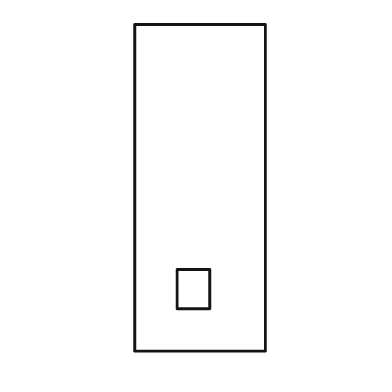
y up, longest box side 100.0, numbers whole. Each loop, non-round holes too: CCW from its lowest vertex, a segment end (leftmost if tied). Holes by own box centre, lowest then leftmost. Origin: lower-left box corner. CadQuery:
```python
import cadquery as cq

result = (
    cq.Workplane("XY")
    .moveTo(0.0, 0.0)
    .lineTo(40.0, 0.0)
    .lineTo(40.0, 100.0)
    .lineTo(0.0, 100.0)
    .close()
    .moveTo(13.0, 13.0)
    .lineTo(23.0, 13.0)
    .lineTo(23.0, 25.0)
    .lineTo(13.0, 25.0)
    .close()
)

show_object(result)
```